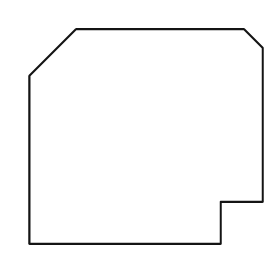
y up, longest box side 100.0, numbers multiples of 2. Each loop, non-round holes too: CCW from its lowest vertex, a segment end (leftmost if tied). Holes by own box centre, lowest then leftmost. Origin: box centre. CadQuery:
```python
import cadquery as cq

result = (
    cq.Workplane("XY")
    .moveTo(-50.0, -46.0)
    .lineTo(32.0, -46.0)
    .lineTo(32.0, -28.0)
    .lineTo(50.0, -28.0)
    .lineTo(50.0, 38.0)
    .lineTo(42.0, 46.0)
    .lineTo(-30.0, 46.0)
    .lineTo(-50.0, 26.0)
    .close()
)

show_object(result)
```